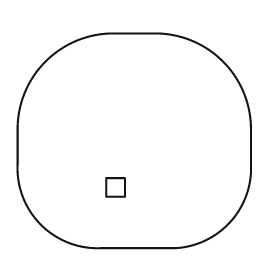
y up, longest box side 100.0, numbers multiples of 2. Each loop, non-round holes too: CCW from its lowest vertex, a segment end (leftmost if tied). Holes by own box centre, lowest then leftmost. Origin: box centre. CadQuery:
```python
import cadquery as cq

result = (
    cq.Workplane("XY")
    .moveTo(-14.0, -46.0)
    .lineTo(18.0, -46.0)
    .threePointArc((40.0, -36.0), (50.0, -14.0))
    .lineTo(50.0, 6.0)
    .threePointArc((38.0, 34.0), (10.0, 46.0))
    .lineTo(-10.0, 46.0)
    .threePointArc((-38.0, 34.0), (-50.0, 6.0))
    .lineTo(-50.0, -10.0)
    .threePointArc((-40.0, -36.0), (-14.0, -46.0))
    .close()
    .moveTo(-12.0, -24.0)
    .lineTo(-4.0, -24.0)
    .lineTo(-4.0, -16.0)
    .lineTo(-12.0, -16.0)
    .close()
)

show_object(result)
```